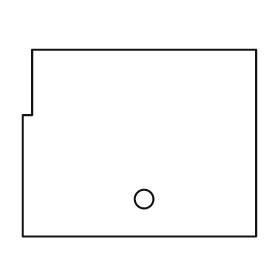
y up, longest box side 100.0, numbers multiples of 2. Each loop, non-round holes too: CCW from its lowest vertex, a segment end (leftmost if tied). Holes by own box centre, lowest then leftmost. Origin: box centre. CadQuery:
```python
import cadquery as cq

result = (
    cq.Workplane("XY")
    .moveTo(-50.0, -40.0)
    .lineTo(50.0, -40.0)
    .lineTo(50.0, 40.0)
    .lineTo(-46.0, 40.0)
    .lineTo(-46.0, 12.0)
    .lineTo(-50.0, 12.0)
    .close()
    .moveTo(2.0, -24.0)
    .circle(4.0)
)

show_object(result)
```